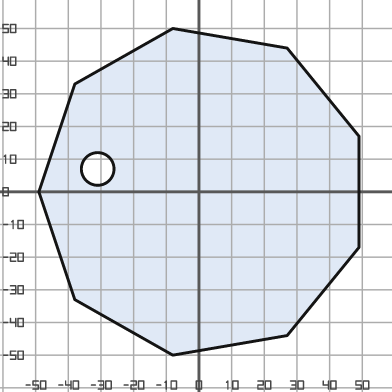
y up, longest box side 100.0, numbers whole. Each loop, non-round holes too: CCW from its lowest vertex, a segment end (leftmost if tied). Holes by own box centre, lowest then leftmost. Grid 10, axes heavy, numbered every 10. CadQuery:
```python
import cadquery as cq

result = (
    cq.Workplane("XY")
    .moveTo(-8.0, -50.0)
    .lineTo(27.0, -44.0)
    .lineTo(49.0, -17.0)
    .lineTo(49.0, 17.0)
    .lineTo(27.0, 44.0)
    .lineTo(-8.0, 50.0)
    .lineTo(-38.0, 33.0)
    .lineTo(-49.0, 0.0)
    .lineTo(-38.0, -33.0)
    .close()
    .moveTo(-31.0, 7.0)
    .circle(5.0)
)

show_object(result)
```